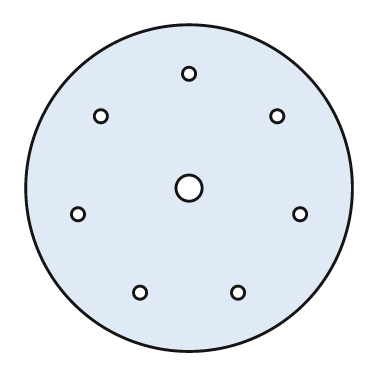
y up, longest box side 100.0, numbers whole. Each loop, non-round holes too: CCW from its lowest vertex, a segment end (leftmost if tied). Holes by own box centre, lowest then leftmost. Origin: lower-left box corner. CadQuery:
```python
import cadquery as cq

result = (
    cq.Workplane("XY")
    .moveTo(50.0, 50.0)
    .circle(50.0)
    .moveTo(35.0, 18.0)
    .circle(2.0)
    .moveTo(65.0, 18.0)
    .circle(2.0)
    .moveTo(16.0, 42.0)
    .circle(2.0)
    .moveTo(84.0, 42.0)
    .circle(2.0)
    .moveTo(50.0, 50.0)
    .circle(4.0)
    .moveTo(23.0, 72.0)
    .circle(2.0)
    .moveTo(77.0, 72.0)
    .circle(2.0)
    .moveTo(50.0, 85.0)
    .circle(2.0)
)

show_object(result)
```